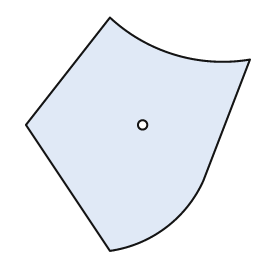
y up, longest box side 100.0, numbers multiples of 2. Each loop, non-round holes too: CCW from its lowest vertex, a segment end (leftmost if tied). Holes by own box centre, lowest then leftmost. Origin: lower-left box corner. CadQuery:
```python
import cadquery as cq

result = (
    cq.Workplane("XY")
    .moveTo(36.0, 0.0)
    .threePointArc((60.0, 10.0), (76.0, 30.0))
    .lineTo(96.0, 82.0)
    .threePointArc((64.0, 84.0), (36.0, 100.0))
    .lineTo(0.0, 54.0)
    .close()
    .moveTo(50.0, 54.0)
    .circle(2.0)
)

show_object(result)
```